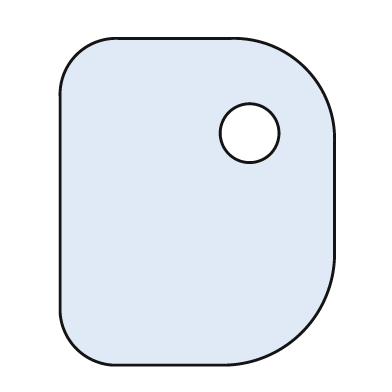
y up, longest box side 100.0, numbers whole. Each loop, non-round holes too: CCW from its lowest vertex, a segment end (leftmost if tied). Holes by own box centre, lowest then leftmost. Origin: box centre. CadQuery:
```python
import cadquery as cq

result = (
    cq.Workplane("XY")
    .moveTo(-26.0, -50.0)
    .lineTo(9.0, -50.0)
    .threePointArc((32.0, -40.0), (42.0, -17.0))
    .lineTo(42.0, 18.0)
    .threePointArc((33.0, 41.0), (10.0, 50.0))
    .lineTo(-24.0, 50.0)
    .threePointArc((-37.0, 45.0), (-42.0, 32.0))
    .lineTo(-42.0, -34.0)
    .threePointArc((-37.0, -45.0), (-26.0, -50.0))
    .close()
    .moveTo(16.0, 21.0)
    .circle(9.0)
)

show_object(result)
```